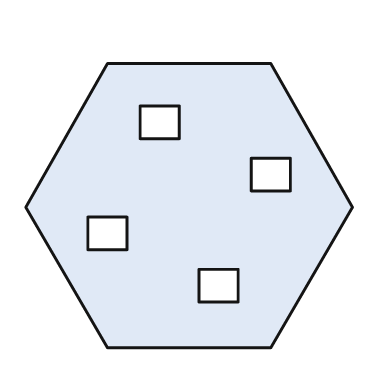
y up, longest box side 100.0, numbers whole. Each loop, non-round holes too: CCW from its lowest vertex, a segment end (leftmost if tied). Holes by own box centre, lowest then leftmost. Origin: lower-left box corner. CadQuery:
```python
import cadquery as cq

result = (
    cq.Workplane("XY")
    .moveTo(25.0, 0.0)
    .lineTo(75.0, 0.0)
    .lineTo(100.0, 43.0)
    .lineTo(75.0, 87.0)
    .lineTo(25.0, 87.0)
    .lineTo(0.0, 43.0)
    .close()
    .moveTo(53.0, 14.0)
    .lineTo(65.0, 14.0)
    .lineTo(65.0, 24.0)
    .lineTo(53.0, 24.0)
    .close()
    .moveTo(19.0, 30.0)
    .lineTo(31.0, 30.0)
    .lineTo(31.0, 40.0)
    .lineTo(19.0, 40.0)
    .close()
    .moveTo(69.0, 48.0)
    .lineTo(81.0, 48.0)
    .lineTo(81.0, 58.0)
    .lineTo(69.0, 58.0)
    .close()
    .moveTo(35.0, 64.0)
    .lineTo(47.0, 64.0)
    .lineTo(47.0, 74.0)
    .lineTo(35.0, 74.0)
    .close()
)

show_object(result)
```